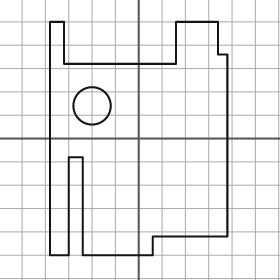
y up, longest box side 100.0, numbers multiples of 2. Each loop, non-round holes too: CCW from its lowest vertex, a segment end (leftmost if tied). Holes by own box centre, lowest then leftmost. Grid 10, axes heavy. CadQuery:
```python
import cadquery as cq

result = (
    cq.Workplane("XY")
    .moveTo(-38.0, -50.0)
    .lineTo(-30.0, -50.0)
    .lineTo(-30.0, -8.0)
    .lineTo(-24.0, -8.0)
    .lineTo(-24.0, -50.0)
    .lineTo(6.0, -50.0)
    .lineTo(6.0, -42.0)
    .lineTo(38.0, -42.0)
    .lineTo(38.0, 36.0)
    .lineTo(34.0, 36.0)
    .lineTo(34.0, 50.0)
    .lineTo(16.0, 50.0)
    .lineTo(16.0, 32.0)
    .lineTo(-32.0, 32.0)
    .lineTo(-32.0, 50.0)
    .lineTo(-38.0, 50.0)
    .close()
    .moveTo(-20.0, 14.0)
    .circle(8.0)
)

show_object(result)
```